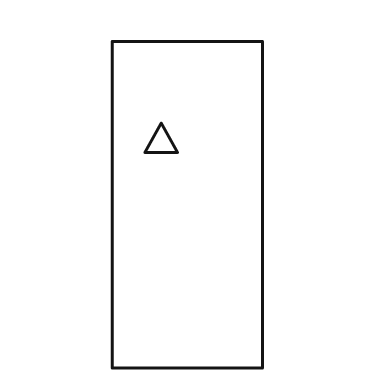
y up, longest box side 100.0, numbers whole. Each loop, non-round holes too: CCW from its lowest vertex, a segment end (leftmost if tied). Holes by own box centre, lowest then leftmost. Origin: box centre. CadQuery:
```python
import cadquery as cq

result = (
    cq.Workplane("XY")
    .moveTo(-23.0, -50.0)
    .lineTo(23.0, -50.0)
    .lineTo(23.0, 50.0)
    .lineTo(-23.0, 50.0)
    .close()
    .moveTo(-13.0, 16.0)
    .lineTo(-3.0, 16.0)
    .lineTo(-8.0, 25.0)
    .close()
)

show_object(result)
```